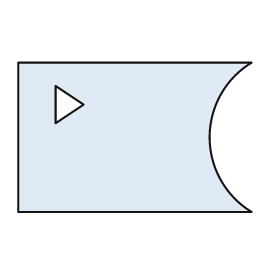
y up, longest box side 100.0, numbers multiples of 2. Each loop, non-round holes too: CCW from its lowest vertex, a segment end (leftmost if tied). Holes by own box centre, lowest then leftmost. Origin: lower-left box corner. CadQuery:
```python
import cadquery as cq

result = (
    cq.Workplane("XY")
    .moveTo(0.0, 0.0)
    .lineTo(100.0, 0.0)
    .threePointArc((82.0, 32.0), (100.0, 64.0))
    .lineTo(0.0, 64.0)
    .close()
    .moveTo(16.0, 38.0)
    .lineTo(28.0, 46.0)
    .lineTo(16.0, 54.0)
    .close()
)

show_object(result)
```